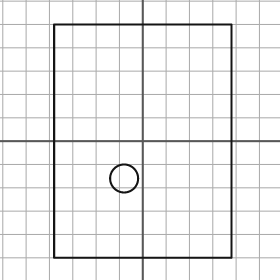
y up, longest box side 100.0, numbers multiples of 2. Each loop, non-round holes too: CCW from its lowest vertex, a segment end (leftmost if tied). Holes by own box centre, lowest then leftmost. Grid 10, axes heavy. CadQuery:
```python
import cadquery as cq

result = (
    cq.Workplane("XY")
    .moveTo(-38.0, -50.0)
    .lineTo(38.0, -50.0)
    .lineTo(38.0, 50.0)
    .lineTo(-38.0, 50.0)
    .close()
    .moveTo(-8.0, -16.0)
    .circle(6.0)
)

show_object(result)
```